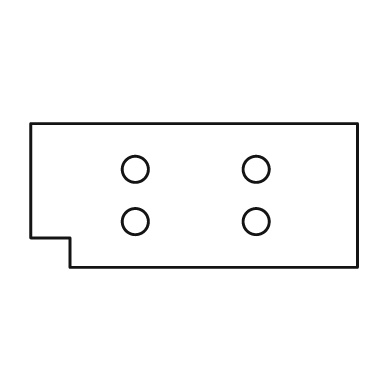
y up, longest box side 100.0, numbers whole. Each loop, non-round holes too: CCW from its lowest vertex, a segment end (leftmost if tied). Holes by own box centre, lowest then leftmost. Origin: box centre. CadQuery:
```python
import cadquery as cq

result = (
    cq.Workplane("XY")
    .moveTo(-38.0, -22.0)
    .lineTo(50.0, -22.0)
    .lineTo(50.0, 22.0)
    .lineTo(-50.0, 22.0)
    .lineTo(-50.0, -13.0)
    .lineTo(-38.0, -13.0)
    .close()
    .moveTo(-18.0, -8.0)
    .circle(4.0)
    .moveTo(19.0, -8.0)
    .circle(4.0)
    .moveTo(-18.0, 8.0)
    .circle(4.0)
    .moveTo(19.0, 8.0)
    .circle(4.0)
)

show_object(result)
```